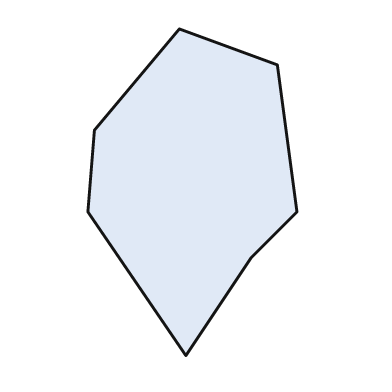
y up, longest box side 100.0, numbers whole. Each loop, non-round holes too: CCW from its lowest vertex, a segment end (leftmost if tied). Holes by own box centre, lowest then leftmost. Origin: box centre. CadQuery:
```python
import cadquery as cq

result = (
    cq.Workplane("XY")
    .moveTo(-2.0, -50.0)
    .lineTo(18.0, -20.0)
    .lineTo(32.0, -6.0)
    .lineTo(26.0, 39.0)
    .lineTo(-4.0, 50.0)
    .lineTo(-30.0, 19.0)
    .lineTo(-32.0, -6.0)
    .close()
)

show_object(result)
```